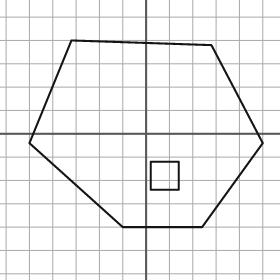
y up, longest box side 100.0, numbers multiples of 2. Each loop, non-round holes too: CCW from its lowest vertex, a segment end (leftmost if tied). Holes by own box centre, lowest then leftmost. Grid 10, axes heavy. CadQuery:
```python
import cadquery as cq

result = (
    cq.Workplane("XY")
    .moveTo(-10.0, -40.0)
    .lineTo(24.0, -40.0)
    .lineTo(50.0, -4.0)
    .lineTo(28.0, 38.0)
    .lineTo(-32.0, 40.0)
    .lineTo(-50.0, -4.0)
    .close()
    .moveTo(2.0, -24.0)
    .lineTo(14.0, -24.0)
    .lineTo(14.0, -12.0)
    .lineTo(2.0, -12.0)
    .close()
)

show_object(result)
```